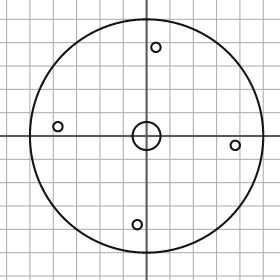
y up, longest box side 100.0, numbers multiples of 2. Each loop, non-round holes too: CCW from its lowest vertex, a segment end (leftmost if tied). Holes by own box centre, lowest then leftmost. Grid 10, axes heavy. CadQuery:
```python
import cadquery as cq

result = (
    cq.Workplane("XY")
    .moveTo(0.0, 0.0)
    .circle(50.0)
    .moveTo(-4.0, -38.0)
    .circle(2.0)
    .moveTo(38.0, -4.0)
    .circle(2.0)
    .moveTo(0.0, 0.0)
    .circle(6.0)
    .moveTo(-38.0, 4.0)
    .circle(2.0)
    .moveTo(4.0, 38.0)
    .circle(2.0)
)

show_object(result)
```